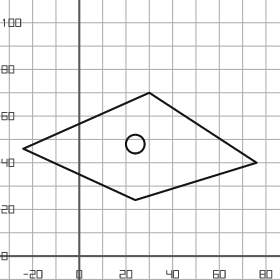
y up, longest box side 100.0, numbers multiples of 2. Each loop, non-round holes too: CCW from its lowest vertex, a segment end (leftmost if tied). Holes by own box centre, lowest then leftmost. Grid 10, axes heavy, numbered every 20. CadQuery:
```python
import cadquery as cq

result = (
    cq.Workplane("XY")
    .moveTo(24.0, 24.0)
    .lineTo(76.0, 40.0)
    .lineTo(30.0, 70.0)
    .lineTo(-24.0, 46.0)
    .close()
    .moveTo(24.0, 48.0)
    .circle(4.0)
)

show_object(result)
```